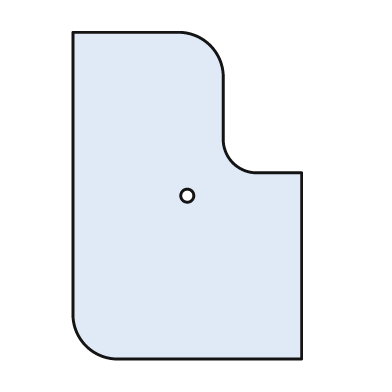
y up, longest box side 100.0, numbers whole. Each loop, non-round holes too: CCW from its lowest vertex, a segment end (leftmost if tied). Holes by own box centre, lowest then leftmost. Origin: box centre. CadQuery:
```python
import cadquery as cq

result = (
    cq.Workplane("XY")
    .moveTo(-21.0, -50.0)
    .lineTo(35.0, -50.0)
    .lineTo(35.0, 7.0)
    .lineTo(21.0, 7.0)
    .threePointArc((14.0, 10.0), (11.0, 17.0))
    .lineTo(11.0, 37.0)
    .threePointArc((7.0, 46.0), (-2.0, 50.0))
    .lineTo(-35.0, 50.0)
    .lineTo(-35.0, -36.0)
    .threePointArc((-31.0, -46.0), (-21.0, -50.0))
    .close()
    .moveTo(0.0, 0.0)
    .circle(2.0)
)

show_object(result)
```